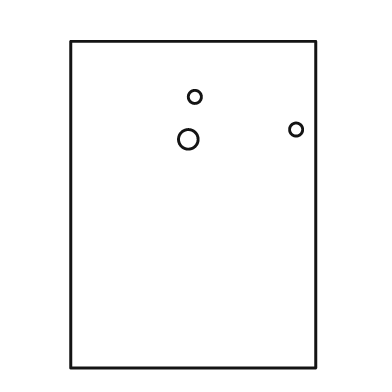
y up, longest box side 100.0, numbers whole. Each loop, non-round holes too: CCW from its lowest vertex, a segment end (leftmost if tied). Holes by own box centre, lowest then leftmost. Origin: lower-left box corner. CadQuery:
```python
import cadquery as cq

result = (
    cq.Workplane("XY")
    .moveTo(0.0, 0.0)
    .lineTo(75.0, 0.0)
    .lineTo(75.0, 100.0)
    .lineTo(0.0, 100.0)
    .close()
    .moveTo(36.0, 70.0)
    .circle(3.0)
    .moveTo(69.0, 73.0)
    .circle(2.0)
    .moveTo(38.0, 83.0)
    .circle(2.0)
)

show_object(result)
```